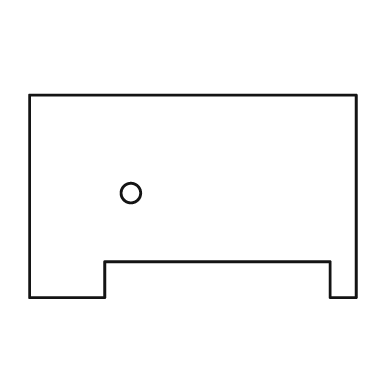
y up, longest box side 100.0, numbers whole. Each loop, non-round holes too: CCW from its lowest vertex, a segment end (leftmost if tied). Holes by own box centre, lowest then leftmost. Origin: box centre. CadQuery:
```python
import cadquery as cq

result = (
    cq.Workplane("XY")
    .moveTo(-50.0, -31.0)
    .lineTo(-27.0, -31.0)
    .lineTo(-27.0, -20.0)
    .lineTo(42.0, -20.0)
    .lineTo(42.0, -31.0)
    .lineTo(50.0, -31.0)
    .lineTo(50.0, 31.0)
    .lineTo(-50.0, 31.0)
    .close()
    .moveTo(-19.0, 1.0)
    .circle(3.0)
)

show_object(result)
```